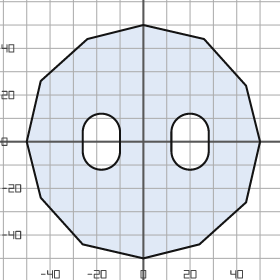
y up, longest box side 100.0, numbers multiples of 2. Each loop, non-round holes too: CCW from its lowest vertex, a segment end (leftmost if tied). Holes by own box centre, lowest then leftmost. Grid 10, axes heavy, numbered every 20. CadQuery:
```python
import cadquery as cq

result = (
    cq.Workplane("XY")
    .moveTo(0.0, -50.0)
    .lineTo(24.0, -44.0)
    .lineTo(44.0, -26.0)
    .lineTo(50.0, 0.0)
    .lineTo(44.0, 24.0)
    .lineTo(26.0, 44.0)
    .lineTo(0.0, 50.0)
    .lineTo(-24.0, 44.0)
    .lineTo(-44.0, 26.0)
    .lineTo(-50.0, 0.0)
    .lineTo(-44.0, -24.0)
    .lineTo(-26.0, -44.0)
    .close()
    .moveTo(-26.0, -4.0)
    .threePointArc((-18.0, -12.0), (-10.0, -4.0))
    .lineTo(-10.0, 4.0)
    .threePointArc((-18.0, 12.0), (-26.0, 4.0))
    .close()
    .moveTo(12.0, -4.0)
    .threePointArc((20.0, -12.0), (28.0, -4.0))
    .lineTo(28.0, 4.0)
    .threePointArc((20.0, 12.0), (12.0, 4.0))
    .close()
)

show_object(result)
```